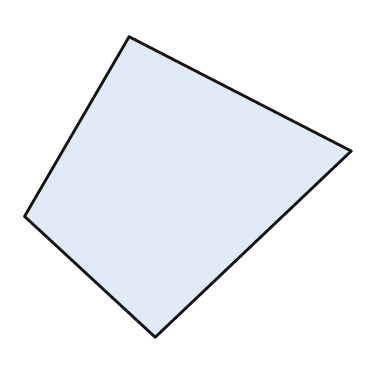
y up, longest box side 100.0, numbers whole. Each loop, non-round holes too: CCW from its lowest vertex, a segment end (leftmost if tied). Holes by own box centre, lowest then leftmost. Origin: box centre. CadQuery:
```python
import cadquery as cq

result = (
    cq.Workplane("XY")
    .moveTo(-10.0, -46.0)
    .lineTo(50.0, 11.0)
    .lineTo(-18.0, 46.0)
    .lineTo(-50.0, -9.0)
    .close()
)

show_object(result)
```